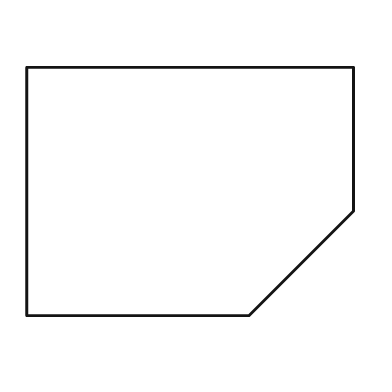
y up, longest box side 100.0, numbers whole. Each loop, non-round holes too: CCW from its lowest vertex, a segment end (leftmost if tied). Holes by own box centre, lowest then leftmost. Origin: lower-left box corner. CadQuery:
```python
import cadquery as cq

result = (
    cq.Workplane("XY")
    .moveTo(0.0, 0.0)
    .lineTo(68.0, 0.0)
    .lineTo(100.0, 32.0)
    .lineTo(100.0, 76.0)
    .lineTo(0.0, 76.0)
    .close()
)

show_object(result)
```